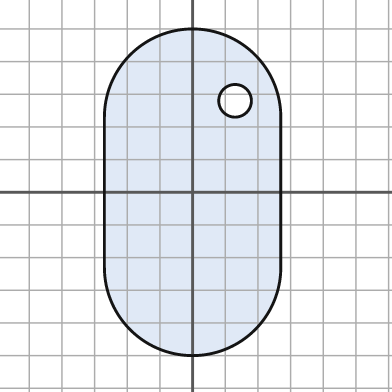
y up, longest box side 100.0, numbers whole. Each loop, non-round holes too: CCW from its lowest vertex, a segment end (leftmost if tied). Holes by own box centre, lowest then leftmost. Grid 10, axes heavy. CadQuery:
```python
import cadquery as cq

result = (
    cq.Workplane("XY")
    .moveTo(-27.0, -23.0)
    .threePointArc((0.0, -50.0), (27.0, -23.0))
    .lineTo(27.0, 23.0)
    .threePointArc((0.0, 50.0), (-27.0, 23.0))
    .close()
    .moveTo(13.0, 28.0)
    .circle(5.0)
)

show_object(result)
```